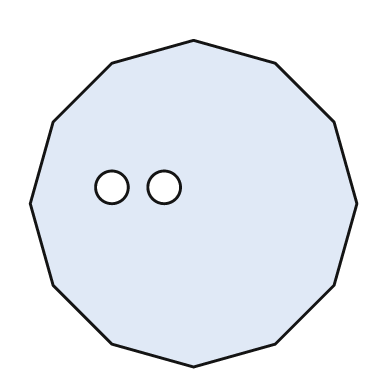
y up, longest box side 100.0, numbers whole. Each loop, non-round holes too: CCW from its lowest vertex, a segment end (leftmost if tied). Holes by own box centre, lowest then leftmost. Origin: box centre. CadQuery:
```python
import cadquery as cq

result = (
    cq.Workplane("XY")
    .moveTo(0.0, -50.0)
    .lineTo(25.0, -43.0)
    .lineTo(43.0, -25.0)
    .lineTo(50.0, 0.0)
    .lineTo(43.0, 25.0)
    .lineTo(25.0, 43.0)
    .lineTo(0.0, 50.0)
    .lineTo(-25.0, 43.0)
    .lineTo(-43.0, 25.0)
    .lineTo(-50.0, 0.0)
    .lineTo(-43.0, -25.0)
    .lineTo(-25.0, -43.0)
    .close()
    .moveTo(-25.0, 5.0)
    .circle(5.0)
    .moveTo(-9.0, 5.0)
    .circle(5.0)
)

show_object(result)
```